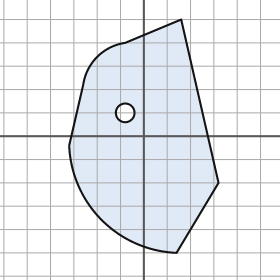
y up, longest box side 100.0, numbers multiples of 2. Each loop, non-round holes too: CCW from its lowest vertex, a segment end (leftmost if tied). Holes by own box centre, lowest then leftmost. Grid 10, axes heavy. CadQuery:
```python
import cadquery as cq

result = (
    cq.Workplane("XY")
    .moveTo(14.0, -50.0)
    .lineTo(32.0, -20.0)
    .lineTo(16.0, 50.0)
    .lineTo(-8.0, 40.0)
    .threePointArc((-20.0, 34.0), (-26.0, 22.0))
    .lineTo(-32.0, -4.0)
    .threePointArc((-18.0, -36.0), (14.0, -50.0))
    .close()
    .moveTo(-8.0, 10.0)
    .circle(4.0)
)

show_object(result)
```